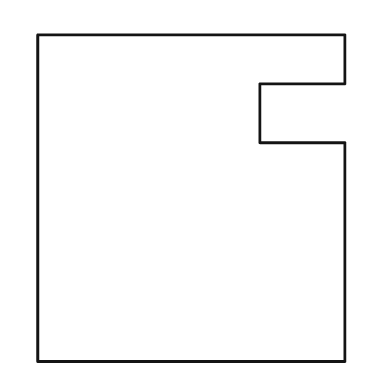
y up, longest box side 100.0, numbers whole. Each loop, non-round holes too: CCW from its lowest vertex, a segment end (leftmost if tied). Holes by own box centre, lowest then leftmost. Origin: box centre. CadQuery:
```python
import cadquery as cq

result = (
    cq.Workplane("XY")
    .moveTo(-47.0, -50.0)
    .lineTo(47.0, -50.0)
    .lineTo(47.0, 17.0)
    .lineTo(21.0, 17.0)
    .lineTo(21.0, 35.0)
    .lineTo(47.0, 35.0)
    .lineTo(47.0, 50.0)
    .lineTo(-47.0, 50.0)
    .close()
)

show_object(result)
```